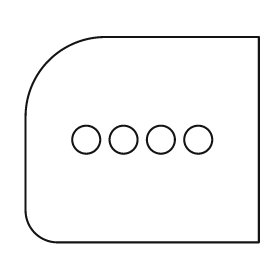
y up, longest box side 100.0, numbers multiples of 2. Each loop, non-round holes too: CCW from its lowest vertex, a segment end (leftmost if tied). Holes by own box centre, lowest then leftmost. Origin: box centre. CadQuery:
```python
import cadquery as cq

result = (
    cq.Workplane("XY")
    .moveTo(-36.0, -44.0)
    .lineTo(50.0, -44.0)
    .lineTo(50.0, 44.0)
    .lineTo(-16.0, 44.0)
    .threePointArc((-40.0, 34.0), (-50.0, 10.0))
    .lineTo(-50.0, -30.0)
    .threePointArc((-46.0, -40.0), (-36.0, -44.0))
    .close()
    .moveTo(-24.0, 0.0)
    .circle(6.0)
    .moveTo(-8.0, 0.0)
    .circle(6.0)
    .moveTo(8.0, 0.0)
    .circle(6.0)
    .moveTo(24.0, 0.0)
    .circle(6.0)
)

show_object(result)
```